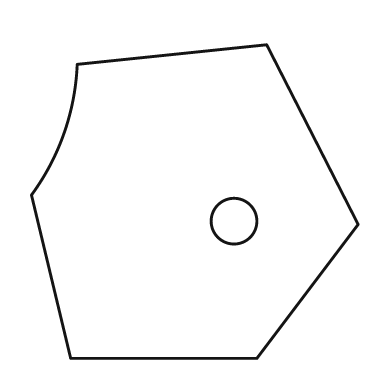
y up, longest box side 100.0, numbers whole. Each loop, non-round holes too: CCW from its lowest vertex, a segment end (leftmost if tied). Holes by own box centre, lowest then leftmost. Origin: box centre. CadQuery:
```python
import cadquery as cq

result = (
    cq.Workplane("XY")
    .moveTo(-38.0, -48.0)
    .lineTo(19.0, -48.0)
    .lineTo(50.0, -7.0)
    .lineTo(22.0, 48.0)
    .lineTo(-36.0, 42.0)
    .threePointArc((-40.0, 21.0), (-50.0, 2.0))
    .close()
    .moveTo(12.0, -6.0)
    .circle(7.0)
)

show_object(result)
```